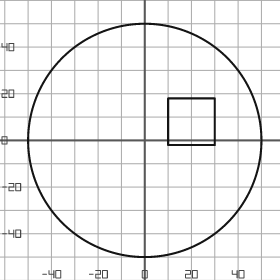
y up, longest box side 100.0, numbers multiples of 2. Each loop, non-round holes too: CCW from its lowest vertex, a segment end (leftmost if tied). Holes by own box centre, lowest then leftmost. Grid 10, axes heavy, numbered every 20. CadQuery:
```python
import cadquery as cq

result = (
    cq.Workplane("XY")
    .moveTo(0.0, 0.0)
    .circle(50.0)
    .moveTo(10.0, -2.0)
    .lineTo(30.0, -2.0)
    .lineTo(30.0, 18.0)
    .lineTo(10.0, 18.0)
    .close()
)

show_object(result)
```